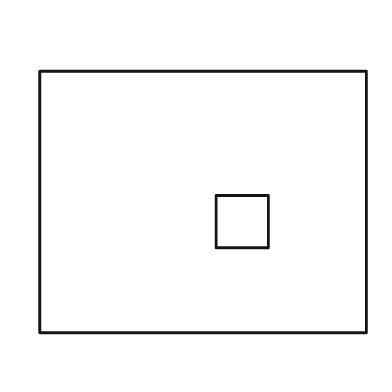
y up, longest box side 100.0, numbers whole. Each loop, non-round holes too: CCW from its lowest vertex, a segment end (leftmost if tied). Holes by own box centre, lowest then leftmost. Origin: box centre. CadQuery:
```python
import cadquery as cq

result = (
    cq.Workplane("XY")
    .moveTo(-50.0, -40.0)
    .lineTo(50.0, -40.0)
    .lineTo(50.0, 40.0)
    .lineTo(-50.0, 40.0)
    .close()
    .moveTo(4.0, -14.0)
    .lineTo(20.0, -14.0)
    .lineTo(20.0, 2.0)
    .lineTo(4.0, 2.0)
    .close()
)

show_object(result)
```